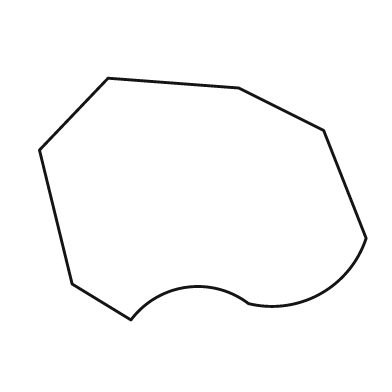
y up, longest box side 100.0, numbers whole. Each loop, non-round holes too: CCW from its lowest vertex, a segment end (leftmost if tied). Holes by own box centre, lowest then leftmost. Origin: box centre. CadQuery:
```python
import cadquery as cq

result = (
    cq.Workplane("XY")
    .moveTo(-22.0, -37.0)
    .threePointArc((-5.0, -27.0), (14.0, -32.0))
    .threePointArc((36.0, -29.0), (50.0, -12.0))
    .lineTo(37.0, 21.0)
    .lineTo(11.0, 34.0)
    .lineTo(-29.0, 37.0)
    .lineTo(-50.0, 15.0)
    .lineTo(-40.0, -26.0)
    .close()
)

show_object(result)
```